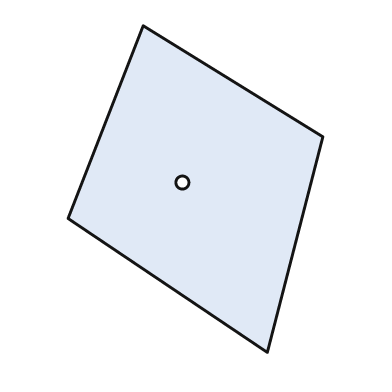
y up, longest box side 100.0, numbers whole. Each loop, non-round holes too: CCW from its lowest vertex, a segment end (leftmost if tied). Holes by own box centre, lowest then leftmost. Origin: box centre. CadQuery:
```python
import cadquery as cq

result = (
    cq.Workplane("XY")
    .moveTo(22.0, -50.0)
    .lineTo(39.0, 16.0)
    .lineTo(-16.0, 50.0)
    .lineTo(-39.0, -9.0)
    .close()
    .moveTo(-4.0, 2.0)
    .circle(2.0)
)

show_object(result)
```